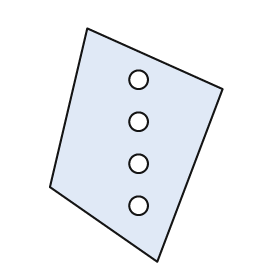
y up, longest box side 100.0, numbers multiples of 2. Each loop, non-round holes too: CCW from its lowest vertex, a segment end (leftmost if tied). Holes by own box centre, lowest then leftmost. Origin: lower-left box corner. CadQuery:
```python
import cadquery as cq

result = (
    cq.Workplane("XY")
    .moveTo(46.0, 0.0)
    .lineTo(74.0, 74.0)
    .lineTo(16.0, 100.0)
    .lineTo(0.0, 32.0)
    .close()
    .moveTo(38.0, 24.0)
    .circle(4.0)
    .moveTo(38.0, 42.0)
    .circle(4.0)
    .moveTo(38.0, 60.0)
    .circle(4.0)
    .moveTo(38.0, 78.0)
    .circle(4.0)
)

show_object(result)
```